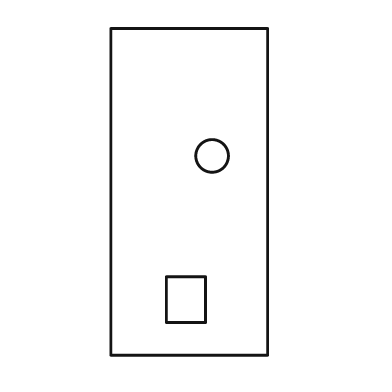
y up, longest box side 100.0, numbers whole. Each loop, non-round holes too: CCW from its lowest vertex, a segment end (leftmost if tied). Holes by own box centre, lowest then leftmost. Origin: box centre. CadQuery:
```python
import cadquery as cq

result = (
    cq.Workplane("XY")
    .moveTo(-24.0, -50.0)
    .lineTo(24.0, -50.0)
    .lineTo(24.0, 50.0)
    .lineTo(-24.0, 50.0)
    .close()
    .moveTo(-7.0, -40.0)
    .lineTo(5.0, -40.0)
    .lineTo(5.0, -26.0)
    .lineTo(-7.0, -26.0)
    .close()
    .moveTo(7.0, 11.0)
    .circle(5.0)
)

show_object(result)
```